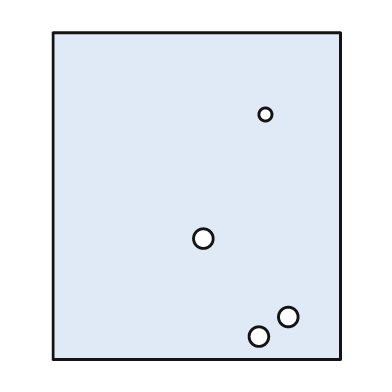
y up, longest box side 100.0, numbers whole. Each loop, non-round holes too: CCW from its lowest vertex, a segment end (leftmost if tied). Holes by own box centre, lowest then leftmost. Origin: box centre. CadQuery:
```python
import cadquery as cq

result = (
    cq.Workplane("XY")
    .moveTo(-44.0, -50.0)
    .lineTo(44.0, -50.0)
    .lineTo(44.0, 50.0)
    .lineTo(-44.0, 50.0)
    .close()
    .moveTo(19.0, -43.0)
    .circle(3.0)
    .moveTo(28.0, -37.0)
    .circle(3.0)
    .moveTo(2.0, -13.0)
    .circle(3.0)
    .moveTo(21.0, 25.0)
    .circle(2.0)
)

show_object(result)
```